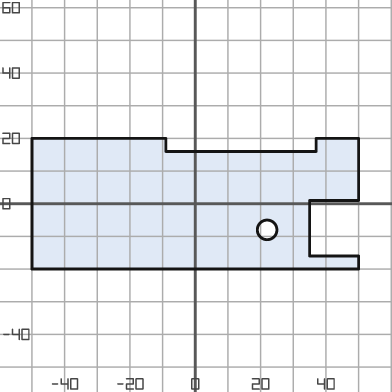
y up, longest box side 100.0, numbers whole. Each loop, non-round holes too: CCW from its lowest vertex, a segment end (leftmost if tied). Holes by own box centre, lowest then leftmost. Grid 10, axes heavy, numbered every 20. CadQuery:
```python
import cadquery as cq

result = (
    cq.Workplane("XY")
    .moveTo(-50.0, -20.0)
    .lineTo(50.0, -20.0)
    .lineTo(50.0, -16.0)
    .lineTo(35.0, -16.0)
    .lineTo(35.0, 1.0)
    .lineTo(50.0, 1.0)
    .lineTo(50.0, 20.0)
    .lineTo(37.0, 20.0)
    .lineTo(37.0, 16.0)
    .lineTo(-9.0, 16.0)
    .lineTo(-9.0, 20.0)
    .lineTo(-50.0, 20.0)
    .close()
    .moveTo(22.0, -8.0)
    .circle(3.0)
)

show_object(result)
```